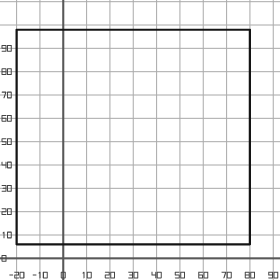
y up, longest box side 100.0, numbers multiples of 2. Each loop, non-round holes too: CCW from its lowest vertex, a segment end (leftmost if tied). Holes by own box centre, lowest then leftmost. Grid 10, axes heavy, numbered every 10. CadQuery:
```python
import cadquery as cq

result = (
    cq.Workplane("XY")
    .moveTo(-20.0, 6.0)
    .lineTo(80.0, 6.0)
    .lineTo(80.0, 98.0)
    .lineTo(-20.0, 98.0)
    .close()
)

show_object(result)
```